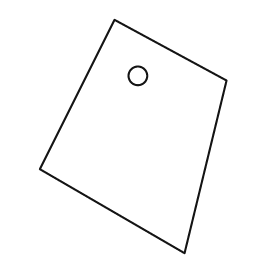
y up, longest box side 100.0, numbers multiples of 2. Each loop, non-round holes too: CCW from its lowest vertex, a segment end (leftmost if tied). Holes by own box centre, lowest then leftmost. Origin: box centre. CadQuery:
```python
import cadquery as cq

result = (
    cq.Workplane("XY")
    .moveTo(22.0, -50.0)
    .lineTo(40.0, 24.0)
    .lineTo(-8.0, 50.0)
    .lineTo(-40.0, -14.0)
    .close()
    .moveTo(2.0, 26.0)
    .circle(4.0)
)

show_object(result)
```